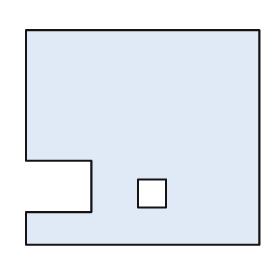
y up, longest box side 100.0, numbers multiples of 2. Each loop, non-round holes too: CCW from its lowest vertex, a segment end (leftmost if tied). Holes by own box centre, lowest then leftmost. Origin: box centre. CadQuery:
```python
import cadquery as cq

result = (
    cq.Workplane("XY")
    .moveTo(-50.0, -46.0)
    .lineTo(50.0, -46.0)
    .lineTo(50.0, 46.0)
    .lineTo(-50.0, 46.0)
    .lineTo(-50.0, -10.0)
    .lineTo(-22.0, -10.0)
    .lineTo(-22.0, -32.0)
    .lineTo(-50.0, -32.0)
    .close()
    .moveTo(-2.0, -30.0)
    .lineTo(10.0, -30.0)
    .lineTo(10.0, -18.0)
    .lineTo(-2.0, -18.0)
    .close()
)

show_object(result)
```